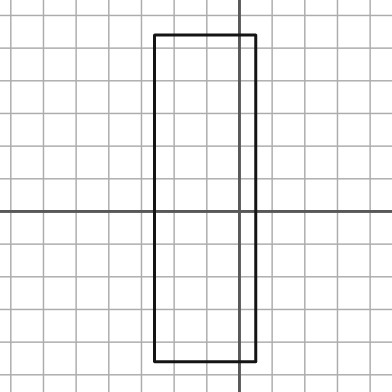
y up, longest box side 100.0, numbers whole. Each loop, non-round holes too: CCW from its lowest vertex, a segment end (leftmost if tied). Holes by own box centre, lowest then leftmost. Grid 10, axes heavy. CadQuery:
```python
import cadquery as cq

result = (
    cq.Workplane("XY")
    .moveTo(-26.0, -46.0)
    .lineTo(5.0, -46.0)
    .lineTo(5.0, 54.0)
    .lineTo(-26.0, 54.0)
    .close()
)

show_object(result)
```